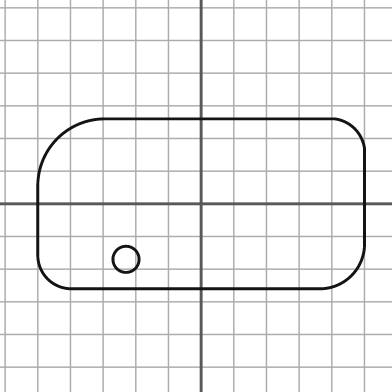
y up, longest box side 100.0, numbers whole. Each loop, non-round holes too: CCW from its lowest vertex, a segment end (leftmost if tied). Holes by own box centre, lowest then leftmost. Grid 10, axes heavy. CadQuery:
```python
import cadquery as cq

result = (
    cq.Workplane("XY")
    .moveTo(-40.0, -26.0)
    .lineTo(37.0, -26.0)
    .threePointArc((46.0, -22.0), (50.0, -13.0))
    .lineTo(50.0, 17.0)
    .threePointArc((47.0, 23.0), (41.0, 26.0))
    .lineTo(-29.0, 26.0)
    .threePointArc((-44.0, 20.0), (-50.0, 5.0))
    .lineTo(-50.0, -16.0)
    .threePointArc((-47.0, -23.0), (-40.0, -26.0))
    .close()
    .moveTo(-23.0, -17.0)
    .circle(4.0)
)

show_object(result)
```